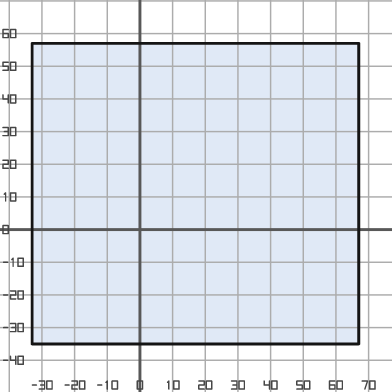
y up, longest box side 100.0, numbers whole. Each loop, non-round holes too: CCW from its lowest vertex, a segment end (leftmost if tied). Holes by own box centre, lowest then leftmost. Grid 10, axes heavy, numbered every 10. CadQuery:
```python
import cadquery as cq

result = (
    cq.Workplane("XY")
    .moveTo(-33.0, -35.0)
    .lineTo(67.0, -35.0)
    .lineTo(67.0, 57.0)
    .lineTo(-33.0, 57.0)
    .close()
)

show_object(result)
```